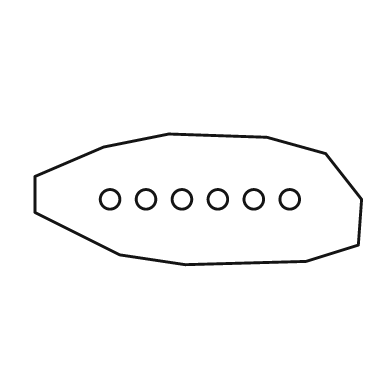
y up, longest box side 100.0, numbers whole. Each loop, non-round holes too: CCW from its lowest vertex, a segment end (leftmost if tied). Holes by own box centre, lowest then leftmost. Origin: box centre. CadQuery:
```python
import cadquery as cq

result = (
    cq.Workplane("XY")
    .moveTo(-4.0, -20.0)
    .lineTo(33.0, -19.0)
    .lineTo(49.0, -14.0)
    .lineTo(50.0, 0.0)
    .lineTo(39.0, 14.0)
    .lineTo(21.0, 19.0)
    .lineTo(-9.0, 20.0)
    .lineTo(-29.0, 16.0)
    .lineTo(-50.0, 7.0)
    .lineTo(-50.0, -4.0)
    .lineTo(-24.0, -17.0)
    .close()
    .moveTo(-27.0, 0.0)
    .circle(3.0)
    .moveTo(-16.0, 0.0)
    .circle(3.0)
    .moveTo(-5.0, 0.0)
    .circle(3.0)
    .moveTo(6.0, 0.0)
    .circle(3.0)
    .moveTo(17.0, 0.0)
    .circle(3.0)
    .moveTo(28.0, 0.0)
    .circle(3.0)
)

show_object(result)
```